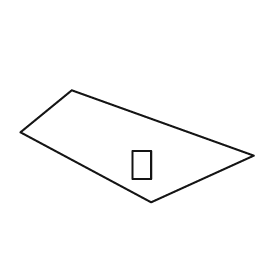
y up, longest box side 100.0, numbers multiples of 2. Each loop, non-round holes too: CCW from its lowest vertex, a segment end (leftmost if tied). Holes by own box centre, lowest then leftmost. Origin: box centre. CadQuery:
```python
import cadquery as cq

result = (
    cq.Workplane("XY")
    .moveTo(6.0, -24.0)
    .lineTo(50.0, -4.0)
    .lineTo(-28.0, 24.0)
    .lineTo(-50.0, 6.0)
    .close()
    .moveTo(-2.0, -14.0)
    .lineTo(6.0, -14.0)
    .lineTo(6.0, -2.0)
    .lineTo(-2.0, -2.0)
    .close()
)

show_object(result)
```